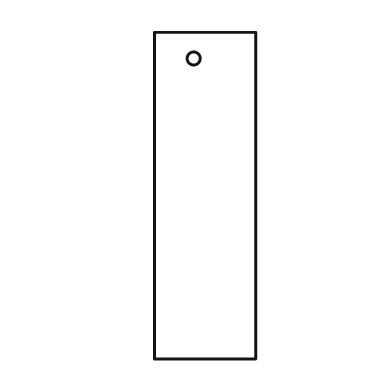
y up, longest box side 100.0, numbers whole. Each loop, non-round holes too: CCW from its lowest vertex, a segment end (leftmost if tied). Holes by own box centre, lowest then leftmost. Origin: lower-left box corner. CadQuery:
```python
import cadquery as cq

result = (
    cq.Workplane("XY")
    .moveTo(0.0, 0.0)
    .lineTo(31.0, 0.0)
    .lineTo(31.0, 100.0)
    .lineTo(0.0, 100.0)
    .close()
    .moveTo(12.0, 92.0)
    .circle(2.0)
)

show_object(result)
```